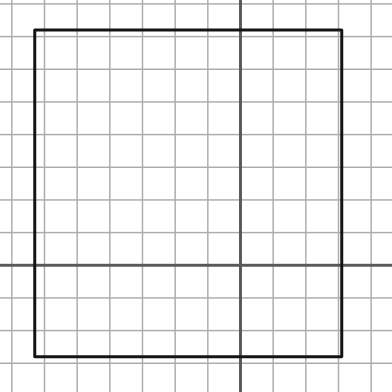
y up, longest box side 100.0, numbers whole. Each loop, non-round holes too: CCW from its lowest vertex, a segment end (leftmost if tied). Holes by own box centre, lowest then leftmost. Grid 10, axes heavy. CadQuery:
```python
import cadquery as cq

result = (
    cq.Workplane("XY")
    .moveTo(-63.0, -28.0)
    .lineTo(31.0, -28.0)
    .lineTo(31.0, 72.0)
    .lineTo(-63.0, 72.0)
    .close()
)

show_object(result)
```